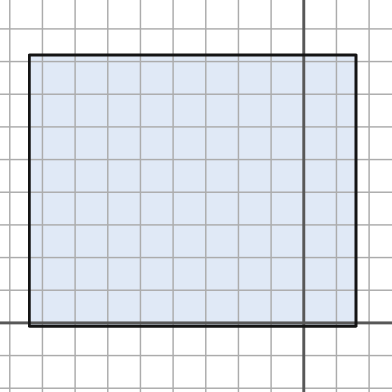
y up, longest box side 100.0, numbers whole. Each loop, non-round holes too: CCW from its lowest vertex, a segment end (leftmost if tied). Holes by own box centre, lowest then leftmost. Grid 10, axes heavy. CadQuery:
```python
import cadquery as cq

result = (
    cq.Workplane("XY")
    .moveTo(-84.0, -1.0)
    .lineTo(16.0, -1.0)
    .lineTo(16.0, 82.0)
    .lineTo(-84.0, 82.0)
    .close()
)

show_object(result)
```